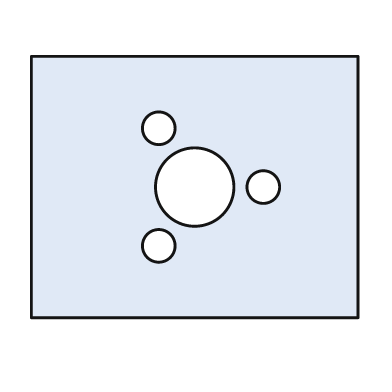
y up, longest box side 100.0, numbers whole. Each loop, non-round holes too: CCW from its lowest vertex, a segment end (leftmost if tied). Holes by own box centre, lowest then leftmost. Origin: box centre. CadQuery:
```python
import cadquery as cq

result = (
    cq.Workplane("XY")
    .moveTo(-50.0, -40.0)
    .lineTo(50.0, -40.0)
    .lineTo(50.0, 40.0)
    .lineTo(-50.0, 40.0)
    .close()
    .moveTo(-11.0, -18.0)
    .circle(5.0)
    .moveTo(0.0, 0.0)
    .circle(12.0)
    .moveTo(21.0, 0.0)
    .circle(5.0)
    .moveTo(-11.0, 18.0)
    .circle(5.0)
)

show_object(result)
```